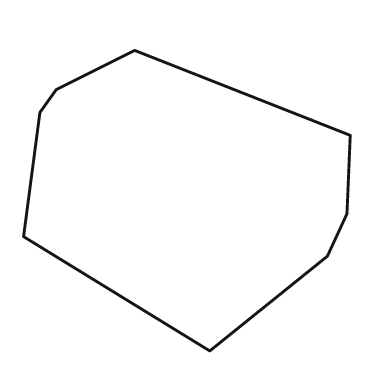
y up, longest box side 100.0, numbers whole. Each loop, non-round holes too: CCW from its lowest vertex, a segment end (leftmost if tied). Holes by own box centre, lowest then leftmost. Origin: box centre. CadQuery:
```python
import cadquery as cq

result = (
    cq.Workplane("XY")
    .moveTo(7.0, -46.0)
    .lineTo(43.0, -17.0)
    .lineTo(49.0, -4.0)
    .lineTo(50.0, 20.0)
    .lineTo(-16.0, 46.0)
    .lineTo(-40.0, 34.0)
    .lineTo(-45.0, 27.0)
    .lineTo(-50.0, -11.0)
    .close()
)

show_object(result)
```